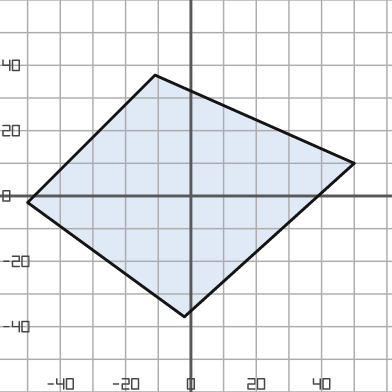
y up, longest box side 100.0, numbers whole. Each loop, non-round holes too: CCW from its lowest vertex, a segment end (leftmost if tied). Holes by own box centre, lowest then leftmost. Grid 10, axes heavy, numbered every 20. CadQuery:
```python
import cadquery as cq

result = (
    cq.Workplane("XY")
    .moveTo(-2.0, -37.0)
    .lineTo(50.0, 10.0)
    .lineTo(-11.0, 37.0)
    .lineTo(-50.0, -2.0)
    .close()
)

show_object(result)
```